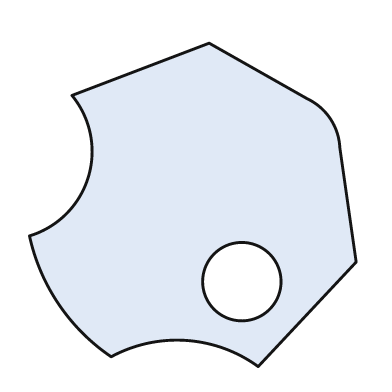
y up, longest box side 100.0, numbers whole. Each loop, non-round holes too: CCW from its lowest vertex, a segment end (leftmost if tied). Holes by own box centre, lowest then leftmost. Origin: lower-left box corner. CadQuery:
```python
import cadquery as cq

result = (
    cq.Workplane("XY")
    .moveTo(70.0, 0.0)
    .lineTo(100.0, 32.0)
    .lineTo(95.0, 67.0)
    .threePointArc((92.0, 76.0), (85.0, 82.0))
    .lineTo(55.0, 99.0)
    .lineTo(13.0, 83.0)
    .threePointArc((18.0, 58.0), (0.0, 40.0))
    .threePointArc((9.0, 19.0), (25.0, 3.0))
    .threePointArc((48.0, 8.0), (70.0, 0.0))
    .close()
    .moveTo(65.0, 26.0)
    .circle(12.0)
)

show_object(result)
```